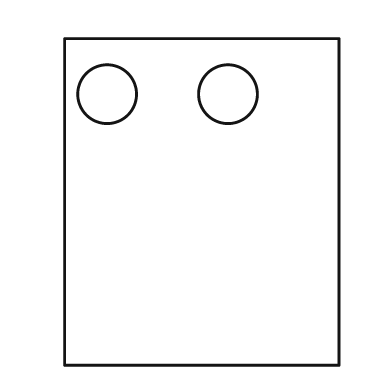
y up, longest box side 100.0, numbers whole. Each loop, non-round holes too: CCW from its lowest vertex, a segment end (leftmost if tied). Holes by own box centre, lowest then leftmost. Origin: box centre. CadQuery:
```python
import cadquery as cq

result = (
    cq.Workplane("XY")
    .moveTo(-42.0, -50.0)
    .lineTo(42.0, -50.0)
    .lineTo(42.0, 50.0)
    .lineTo(-42.0, 50.0)
    .close()
    .moveTo(-29.0, 33.0)
    .circle(9.0)
    .moveTo(8.0, 33.0)
    .circle(9.0)
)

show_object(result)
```